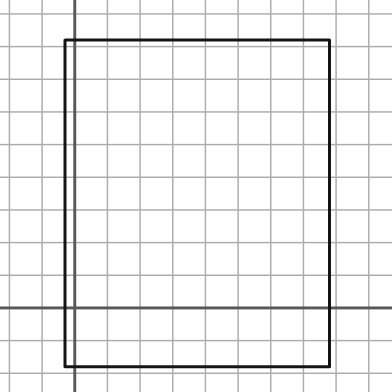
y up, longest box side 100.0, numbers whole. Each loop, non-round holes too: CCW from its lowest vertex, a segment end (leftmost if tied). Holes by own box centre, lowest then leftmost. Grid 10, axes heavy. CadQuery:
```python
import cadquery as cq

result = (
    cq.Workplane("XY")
    .moveTo(-3.0, -18.0)
    .lineTo(78.0, -18.0)
    .lineTo(78.0, 82.0)
    .lineTo(-3.0, 82.0)
    .close()
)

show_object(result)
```